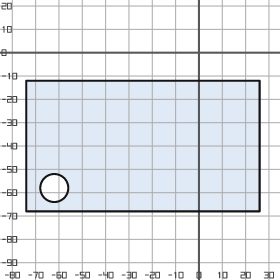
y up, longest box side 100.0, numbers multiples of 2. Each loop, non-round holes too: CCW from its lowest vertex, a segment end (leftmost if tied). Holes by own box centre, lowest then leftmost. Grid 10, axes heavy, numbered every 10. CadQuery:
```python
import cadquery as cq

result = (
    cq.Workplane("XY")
    .moveTo(-74.0, -68.0)
    .lineTo(26.0, -68.0)
    .lineTo(26.0, -12.0)
    .lineTo(-74.0, -12.0)
    .close()
    .moveTo(-62.0, -58.0)
    .circle(6.0)
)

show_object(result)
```